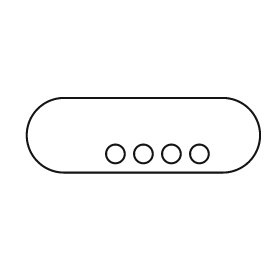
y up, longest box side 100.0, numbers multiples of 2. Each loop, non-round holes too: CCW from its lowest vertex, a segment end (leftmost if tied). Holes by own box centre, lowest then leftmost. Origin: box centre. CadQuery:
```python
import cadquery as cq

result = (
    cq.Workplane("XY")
    .moveTo(-34.0, -16.0)
    .lineTo(34.0, -16.0)
    .threePointArc((50.0, 0.0), (34.0, 16.0))
    .lineTo(-34.0, 16.0)
    .threePointArc((-50.0, 0.0), (-34.0, -16.0))
    .close()
    .moveTo(-12.0, -8.0)
    .circle(4.0)
    .moveTo(0.0, -8.0)
    .circle(4.0)
    .moveTo(12.0, -8.0)
    .circle(4.0)
    .moveTo(24.0, -8.0)
    .circle(4.0)
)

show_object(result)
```